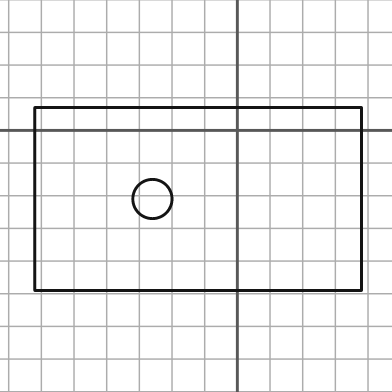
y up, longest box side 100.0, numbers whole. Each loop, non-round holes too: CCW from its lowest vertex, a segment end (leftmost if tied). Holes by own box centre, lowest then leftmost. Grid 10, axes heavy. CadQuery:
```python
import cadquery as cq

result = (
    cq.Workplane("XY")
    .moveTo(-62.0, -49.0)
    .lineTo(38.0, -49.0)
    .lineTo(38.0, 7.0)
    .lineTo(-62.0, 7.0)
    .close()
    .moveTo(-26.0, -21.0)
    .circle(6.0)
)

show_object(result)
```